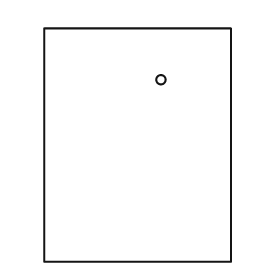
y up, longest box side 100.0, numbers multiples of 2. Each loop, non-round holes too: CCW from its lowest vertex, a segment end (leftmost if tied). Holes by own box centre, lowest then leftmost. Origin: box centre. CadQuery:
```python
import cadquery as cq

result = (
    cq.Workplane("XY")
    .moveTo(-40.0, -50.0)
    .lineTo(40.0, -50.0)
    .lineTo(40.0, 50.0)
    .lineTo(-40.0, 50.0)
    .close()
    .moveTo(10.0, 28.0)
    .circle(2.0)
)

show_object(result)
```